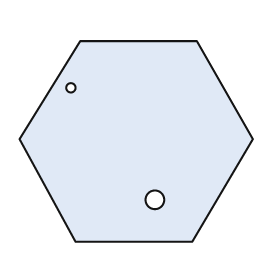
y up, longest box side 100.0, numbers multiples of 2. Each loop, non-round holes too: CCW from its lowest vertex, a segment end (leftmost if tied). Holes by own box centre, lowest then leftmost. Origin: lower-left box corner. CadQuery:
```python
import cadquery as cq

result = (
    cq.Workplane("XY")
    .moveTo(24.0, 0.0)
    .lineTo(74.0, 0.0)
    .lineTo(100.0, 44.0)
    .lineTo(76.0, 86.0)
    .lineTo(26.0, 86.0)
    .lineTo(0.0, 44.0)
    .close()
    .moveTo(58.0, 18.0)
    .circle(4.0)
    .moveTo(22.0, 66.0)
    .circle(2.0)
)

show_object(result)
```